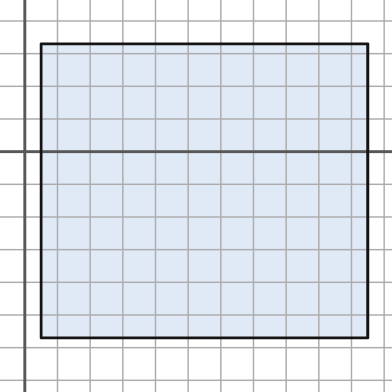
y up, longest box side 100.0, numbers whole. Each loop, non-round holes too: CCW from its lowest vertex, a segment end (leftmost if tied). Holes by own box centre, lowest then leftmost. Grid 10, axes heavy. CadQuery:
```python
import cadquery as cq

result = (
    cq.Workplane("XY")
    .moveTo(5.0, -57.0)
    .lineTo(105.0, -57.0)
    .lineTo(105.0, 33.0)
    .lineTo(5.0, 33.0)
    .close()
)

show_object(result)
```